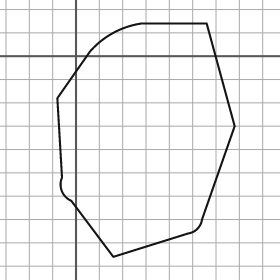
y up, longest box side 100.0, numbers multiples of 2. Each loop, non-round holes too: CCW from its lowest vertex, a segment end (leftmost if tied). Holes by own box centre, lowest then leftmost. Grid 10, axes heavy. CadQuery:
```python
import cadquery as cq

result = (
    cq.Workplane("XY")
    .moveTo(16.0, -86.0)
    .lineTo(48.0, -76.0)
    .threePointArc((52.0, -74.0), (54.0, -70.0))
    .lineTo(68.0, -30.0)
    .lineTo(56.0, 14.0)
    .lineTo(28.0, 14.0)
    .threePointArc((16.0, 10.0), (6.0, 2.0))
    .lineTo(-8.0, -18.0)
    .lineTo(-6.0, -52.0)
    .threePointArc((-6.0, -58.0), (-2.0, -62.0))
    .close()
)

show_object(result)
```